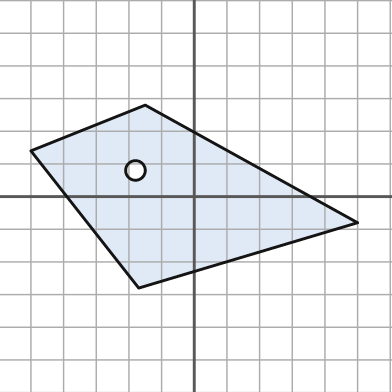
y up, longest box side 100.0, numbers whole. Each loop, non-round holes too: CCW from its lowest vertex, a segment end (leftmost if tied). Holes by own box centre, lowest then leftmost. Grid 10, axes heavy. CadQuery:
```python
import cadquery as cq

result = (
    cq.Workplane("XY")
    .moveTo(-17.0, -28.0)
    .lineTo(50.0, -8.0)
    .lineTo(-15.0, 28.0)
    .lineTo(-50.0, 14.0)
    .close()
    .moveTo(-18.0, 8.0)
    .circle(3.0)
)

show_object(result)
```